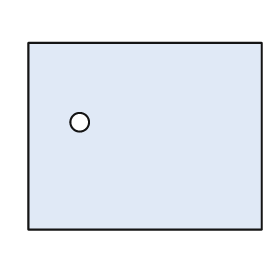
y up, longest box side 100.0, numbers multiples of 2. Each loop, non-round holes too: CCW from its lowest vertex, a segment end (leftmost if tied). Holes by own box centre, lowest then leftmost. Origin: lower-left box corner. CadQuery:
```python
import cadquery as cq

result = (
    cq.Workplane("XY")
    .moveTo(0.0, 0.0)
    .lineTo(100.0, 0.0)
    .lineTo(100.0, 80.0)
    .lineTo(0.0, 80.0)
    .close()
    .moveTo(22.0, 46.0)
    .circle(4.0)
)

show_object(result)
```